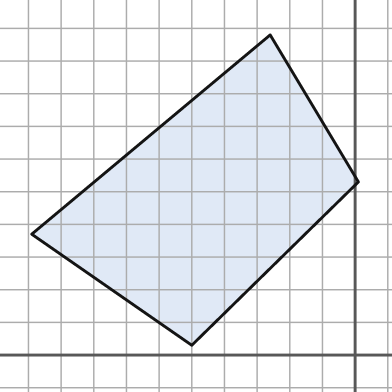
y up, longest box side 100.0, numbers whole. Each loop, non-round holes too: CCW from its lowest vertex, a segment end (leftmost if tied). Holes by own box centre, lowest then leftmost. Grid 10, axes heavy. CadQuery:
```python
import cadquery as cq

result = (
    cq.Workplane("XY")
    .moveTo(-50.0, 3.0)
    .lineTo(1.0, 53.0)
    .lineTo(-26.0, 98.0)
    .lineTo(-99.0, 37.0)
    .close()
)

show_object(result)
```